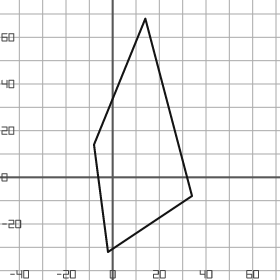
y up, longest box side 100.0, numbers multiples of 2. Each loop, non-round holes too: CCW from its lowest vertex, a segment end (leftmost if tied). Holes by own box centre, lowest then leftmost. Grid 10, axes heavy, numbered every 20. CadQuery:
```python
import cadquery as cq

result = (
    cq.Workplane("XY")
    .moveTo(-2.0, -32.0)
    .lineTo(34.0, -8.0)
    .lineTo(14.0, 68.0)
    .lineTo(-8.0, 14.0)
    .close()
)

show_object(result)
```